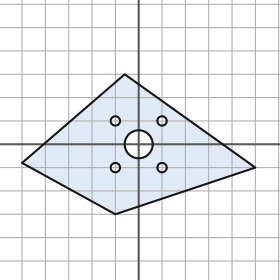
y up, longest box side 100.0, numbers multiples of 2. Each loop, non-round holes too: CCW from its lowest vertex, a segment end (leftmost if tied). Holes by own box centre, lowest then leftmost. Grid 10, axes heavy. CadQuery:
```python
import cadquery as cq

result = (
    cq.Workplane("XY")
    .moveTo(-10.0, -30.0)
    .lineTo(50.0, -10.0)
    .lineTo(-6.0, 30.0)
    .lineTo(-50.0, -8.0)
    .close()
    .moveTo(-10.0, -10.0)
    .circle(2.0)
    .moveTo(10.0, -10.0)
    .circle(2.0)
    .moveTo(0.0, 0.0)
    .circle(6.0)
    .moveTo(-10.0, 10.0)
    .circle(2.0)
    .moveTo(10.0, 10.0)
    .circle(2.0)
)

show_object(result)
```